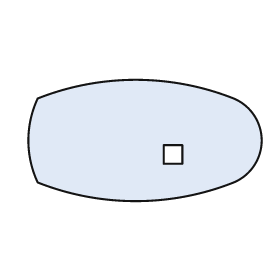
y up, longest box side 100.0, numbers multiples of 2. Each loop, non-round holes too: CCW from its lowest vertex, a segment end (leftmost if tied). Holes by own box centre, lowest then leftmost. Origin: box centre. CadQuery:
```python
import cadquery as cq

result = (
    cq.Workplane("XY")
    .moveTo(-46.0, -18.0)
    .threePointArc((-4.0, -26.0), (38.0, -18.0))
    .threePointArc((50.0, 0.0), (38.0, 18.0))
    .threePointArc((-4.0, 26.0), (-46.0, 18.0))
    .threePointArc((-50.0, 0.0), (-46.0, -18.0))
    .close()
    .moveTo(8.0, -10.0)
    .lineTo(16.0, -10.0)
    .lineTo(16.0, -2.0)
    .lineTo(8.0, -2.0)
    .close()
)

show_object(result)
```